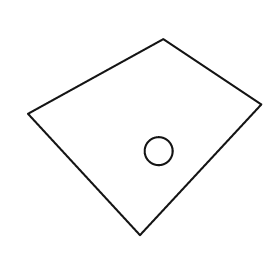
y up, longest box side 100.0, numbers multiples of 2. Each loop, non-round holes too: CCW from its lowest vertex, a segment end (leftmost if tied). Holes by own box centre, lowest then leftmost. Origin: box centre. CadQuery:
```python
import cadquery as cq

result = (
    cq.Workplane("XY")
    .moveTo(-2.0, -42.0)
    .lineTo(50.0, 14.0)
    .lineTo(8.0, 42.0)
    .lineTo(-50.0, 10.0)
    .close()
    .moveTo(6.0, -6.0)
    .circle(6.0)
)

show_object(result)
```